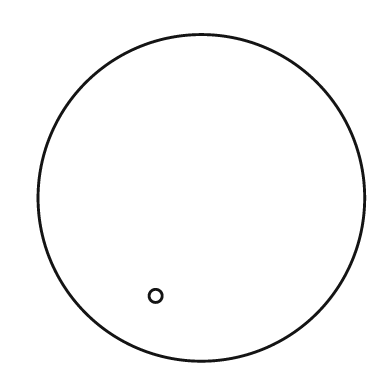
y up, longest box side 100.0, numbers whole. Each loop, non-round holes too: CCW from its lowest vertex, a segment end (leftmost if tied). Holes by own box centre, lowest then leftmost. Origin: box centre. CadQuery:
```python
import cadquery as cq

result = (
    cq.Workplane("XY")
    .moveTo(0.0, 0.0)
    .circle(50.0)
    .moveTo(-14.0, -30.0)
    .circle(2.0)
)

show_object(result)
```